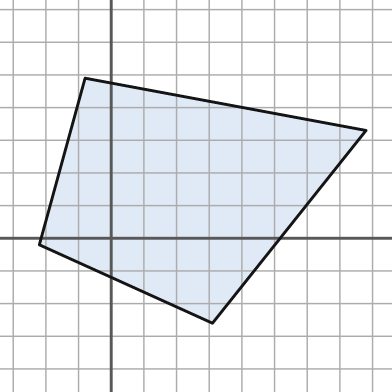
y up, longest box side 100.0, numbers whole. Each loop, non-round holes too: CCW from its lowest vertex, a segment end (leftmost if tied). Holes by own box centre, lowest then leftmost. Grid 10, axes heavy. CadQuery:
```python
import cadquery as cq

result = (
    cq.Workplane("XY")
    .moveTo(31.0, -26.0)
    .lineTo(78.0, 33.0)
    .lineTo(-8.0, 49.0)
    .lineTo(-22.0, -2.0)
    .close()
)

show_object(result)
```